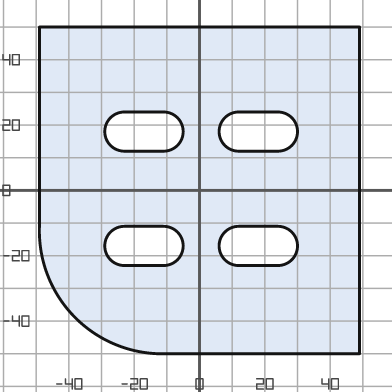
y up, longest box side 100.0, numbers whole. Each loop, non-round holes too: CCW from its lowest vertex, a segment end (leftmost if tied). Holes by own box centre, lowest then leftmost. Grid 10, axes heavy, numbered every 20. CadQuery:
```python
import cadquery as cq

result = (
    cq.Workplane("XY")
    .moveTo(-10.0, -50.0)
    .lineTo(49.0, -50.0)
    .lineTo(49.0, 50.0)
    .lineTo(-49.0, 50.0)
    .lineTo(-49.0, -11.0)
    .threePointArc((-38.0, -39.0), (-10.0, -50.0))
    .close()
    .moveTo(-23.0, -23.0)
    .lineTo(-11.0, -23.0)
    .threePointArc((-5.0, -17.0), (-11.0, -11.0))
    .lineTo(-23.0, -11.0)
    .threePointArc((-29.0, -17.0), (-23.0, -23.0))
    .close()
    .moveTo(12.0, -23.0)
    .lineTo(24.0, -23.0)
    .threePointArc((30.0, -17.0), (24.0, -11.0))
    .lineTo(12.0, -11.0)
    .threePointArc((6.0, -17.0), (12.0, -23.0))
    .close()
    .moveTo(-23.0, 12.0)
    .lineTo(-11.0, 12.0)
    .threePointArc((-5.0, 18.0), (-11.0, 24.0))
    .lineTo(-23.0, 24.0)
    .threePointArc((-29.0, 18.0), (-23.0, 12.0))
    .close()
    .moveTo(12.0, 12.0)
    .lineTo(24.0, 12.0)
    .threePointArc((30.0, 18.0), (24.0, 24.0))
    .lineTo(12.0, 24.0)
    .threePointArc((6.0, 18.0), (12.0, 12.0))
    .close()
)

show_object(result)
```